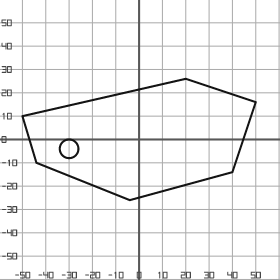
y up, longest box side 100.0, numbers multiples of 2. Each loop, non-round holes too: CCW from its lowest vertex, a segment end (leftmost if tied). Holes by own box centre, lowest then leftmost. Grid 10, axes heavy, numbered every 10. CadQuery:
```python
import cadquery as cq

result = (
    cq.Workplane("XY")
    .moveTo(-4.0, -26.0)
    .lineTo(40.0, -14.0)
    .lineTo(50.0, 16.0)
    .lineTo(20.0, 26.0)
    .lineTo(-50.0, 10.0)
    .lineTo(-44.0, -10.0)
    .close()
    .moveTo(-30.0, -4.0)
    .circle(4.0)
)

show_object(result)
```